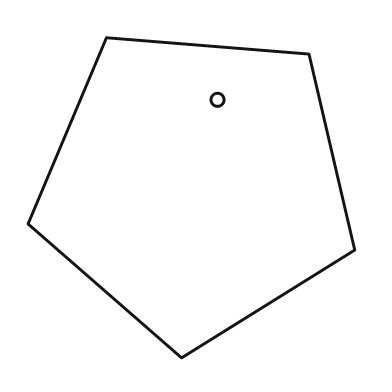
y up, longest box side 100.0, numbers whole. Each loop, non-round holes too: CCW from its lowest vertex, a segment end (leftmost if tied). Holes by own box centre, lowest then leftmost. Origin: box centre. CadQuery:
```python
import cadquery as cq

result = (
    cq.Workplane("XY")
    .moveTo(-3.0, -49.0)
    .lineTo(50.0, -16.0)
    .lineTo(36.0, 44.0)
    .lineTo(-26.0, 49.0)
    .lineTo(-50.0, -8.0)
    .close()
    .moveTo(8.0, 30.0)
    .circle(2.0)
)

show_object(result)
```